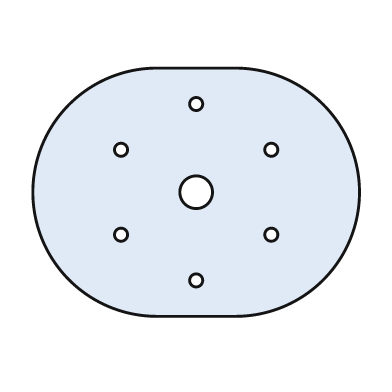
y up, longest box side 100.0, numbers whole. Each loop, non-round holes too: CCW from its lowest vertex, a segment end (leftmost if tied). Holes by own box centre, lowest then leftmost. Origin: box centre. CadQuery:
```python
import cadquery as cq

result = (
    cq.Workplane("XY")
    .moveTo(-12.0, -38.0)
    .lineTo(12.0, -38.0)
    .threePointArc((50.0, 0.0), (12.0, 38.0))
    .lineTo(-12.0, 38.0)
    .threePointArc((-50.0, 0.0), (-12.0, -38.0))
    .close()
    .moveTo(0.0, -27.0)
    .circle(2.0)
    .moveTo(-23.0, -13.0)
    .circle(2.0)
    .moveTo(23.0, -13.0)
    .circle(2.0)
    .moveTo(0.0, 0.0)
    .circle(5.0)
    .moveTo(-23.0, 13.0)
    .circle(2.0)
    .moveTo(23.0, 13.0)
    .circle(2.0)
    .moveTo(0.0, 27.0)
    .circle(2.0)
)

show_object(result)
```